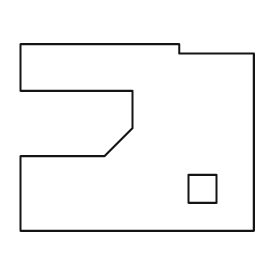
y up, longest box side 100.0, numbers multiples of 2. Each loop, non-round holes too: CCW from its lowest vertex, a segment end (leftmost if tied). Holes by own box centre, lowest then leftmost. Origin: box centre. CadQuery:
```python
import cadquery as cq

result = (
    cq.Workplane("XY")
    .moveTo(-50.0, -40.0)
    .lineTo(50.0, -40.0)
    .lineTo(50.0, 36.0)
    .lineTo(18.0, 36.0)
    .lineTo(18.0, 40.0)
    .lineTo(-50.0, 40.0)
    .lineTo(-50.0, 20.0)
    .lineTo(-2.0, 20.0)
    .lineTo(-2.0, 4.0)
    .lineTo(-14.0, -8.0)
    .lineTo(-50.0, -8.0)
    .close()
    .moveTo(22.0, -28.0)
    .lineTo(34.0, -28.0)
    .lineTo(34.0, -16.0)
    .lineTo(22.0, -16.0)
    .close()
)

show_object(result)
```